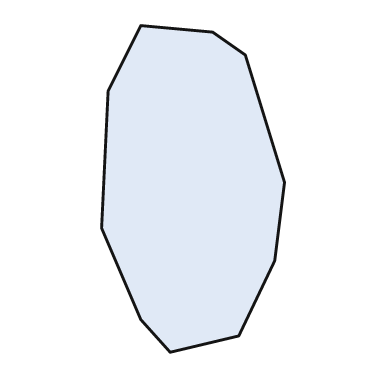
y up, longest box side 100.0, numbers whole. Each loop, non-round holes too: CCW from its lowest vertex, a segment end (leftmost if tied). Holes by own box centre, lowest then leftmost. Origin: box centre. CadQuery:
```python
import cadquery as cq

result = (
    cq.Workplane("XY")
    .moveTo(-7.0, -50.0)
    .lineTo(14.0, -45.0)
    .lineTo(25.0, -22.0)
    .lineTo(28.0, 2.0)
    .lineTo(16.0, 41.0)
    .lineTo(6.0, 48.0)
    .lineTo(-16.0, 50.0)
    .lineTo(-26.0, 30.0)
    .lineTo(-28.0, -12.0)
    .lineTo(-16.0, -40.0)
    .close()
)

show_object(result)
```